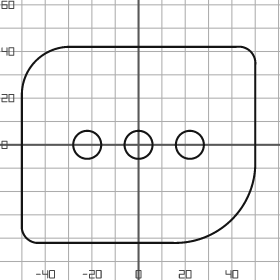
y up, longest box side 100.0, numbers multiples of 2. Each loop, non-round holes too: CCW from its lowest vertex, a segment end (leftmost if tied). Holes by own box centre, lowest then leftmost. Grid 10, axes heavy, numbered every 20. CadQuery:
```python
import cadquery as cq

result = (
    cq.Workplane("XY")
    .moveTo(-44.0, -42.0)
    .lineTo(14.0, -42.0)
    .threePointArc((40.0, -32.0), (50.0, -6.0))
    .lineTo(50.0, 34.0)
    .threePointArc((48.0, 40.0), (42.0, 42.0))
    .lineTo(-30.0, 42.0)
    .threePointArc((-44.0, 36.0), (-50.0, 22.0))
    .lineTo(-50.0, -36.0)
    .threePointArc((-48.0, -40.0), (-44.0, -42.0))
    .close()
    .moveTo(-22.0, 0.0)
    .circle(6.0)
    .moveTo(0.0, 0.0)
    .circle(6.0)
    .moveTo(22.0, 0.0)
    .circle(6.0)
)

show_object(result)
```